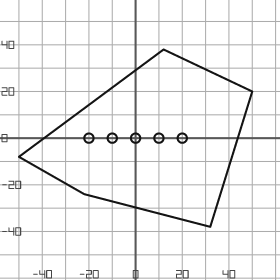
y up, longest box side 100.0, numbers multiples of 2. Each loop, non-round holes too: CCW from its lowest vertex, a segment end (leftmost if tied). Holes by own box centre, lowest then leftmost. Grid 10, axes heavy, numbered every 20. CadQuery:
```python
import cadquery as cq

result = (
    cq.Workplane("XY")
    .moveTo(32.0, -38.0)
    .lineTo(50.0, 20.0)
    .lineTo(12.0, 38.0)
    .lineTo(-50.0, -8.0)
    .lineTo(-22.0, -24.0)
    .close()
    .moveTo(-20.0, 0.0)
    .circle(2.0)
    .moveTo(-10.0, 0.0)
    .circle(2.0)
    .moveTo(0.0, 0.0)
    .circle(2.0)
    .moveTo(10.0, 0.0)
    .circle(2.0)
    .moveTo(20.0, 0.0)
    .circle(2.0)
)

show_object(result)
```